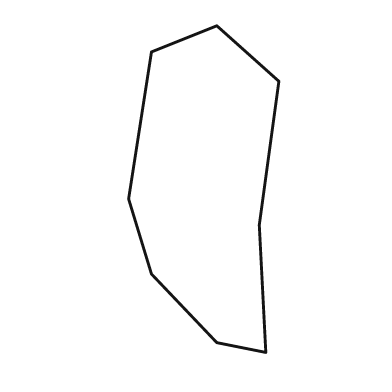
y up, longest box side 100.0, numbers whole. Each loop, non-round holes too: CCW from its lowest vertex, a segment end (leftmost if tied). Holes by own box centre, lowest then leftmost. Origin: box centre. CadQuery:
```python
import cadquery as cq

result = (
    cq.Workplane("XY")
    .moveTo(19.0, -50.0)
    .lineTo(17.0, -11.0)
    .lineTo(23.0, 33.0)
    .lineTo(4.0, 50.0)
    .lineTo(-16.0, 42.0)
    .lineTo(-23.0, -3.0)
    .lineTo(-16.0, -26.0)
    .lineTo(4.0, -47.0)
    .close()
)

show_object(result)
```